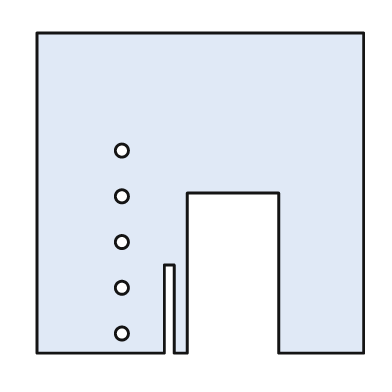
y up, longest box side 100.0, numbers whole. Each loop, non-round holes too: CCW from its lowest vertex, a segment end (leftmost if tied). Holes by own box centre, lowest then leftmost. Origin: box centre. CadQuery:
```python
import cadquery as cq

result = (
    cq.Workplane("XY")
    .moveTo(-50.0, -49.0)
    .lineTo(-11.0, -49.0)
    .lineTo(-11.0, -22.0)
    .lineTo(-8.0, -22.0)
    .lineTo(-8.0, -49.0)
    .lineTo(-4.0, -49.0)
    .lineTo(-4.0, 0.0)
    .lineTo(24.0, 0.0)
    .lineTo(24.0, -49.0)
    .lineTo(50.0, -49.0)
    .lineTo(50.0, 49.0)
    .lineTo(-50.0, 49.0)
    .close()
    .moveTo(-24.0, -43.0)
    .circle(2.0)
    .moveTo(-24.0, -29.0)
    .circle(2.0)
    .moveTo(-24.0, -15.0)
    .circle(2.0)
    .moveTo(-24.0, -1.0)
    .circle(2.0)
    .moveTo(-24.0, 13.0)
    .circle(2.0)
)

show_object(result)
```